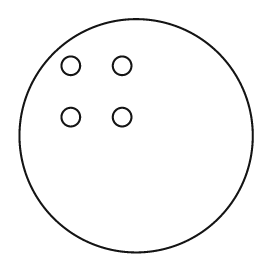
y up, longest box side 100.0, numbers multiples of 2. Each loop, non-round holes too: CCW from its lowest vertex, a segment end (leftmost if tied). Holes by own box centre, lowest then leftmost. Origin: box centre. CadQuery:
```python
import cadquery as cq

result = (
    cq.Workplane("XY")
    .moveTo(0.0, 0.0)
    .circle(50.0)
    .moveTo(-28.0, 8.0)
    .circle(4.0)
    .moveTo(-6.0, 8.0)
    .circle(4.0)
    .moveTo(-28.0, 30.0)
    .circle(4.0)
    .moveTo(-6.0, 30.0)
    .circle(4.0)
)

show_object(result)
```